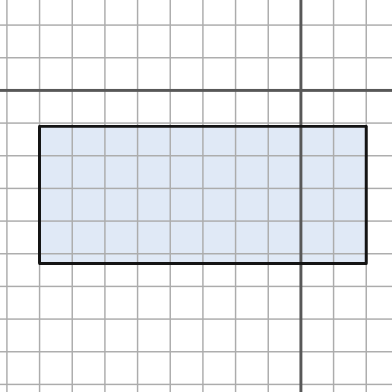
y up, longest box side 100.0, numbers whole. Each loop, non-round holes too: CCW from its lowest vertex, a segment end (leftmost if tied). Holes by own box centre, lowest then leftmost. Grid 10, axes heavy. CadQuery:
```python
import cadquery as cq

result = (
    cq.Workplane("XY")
    .moveTo(-80.0, -53.0)
    .lineTo(20.0, -53.0)
    .lineTo(20.0, -11.0)
    .lineTo(-80.0, -11.0)
    .close()
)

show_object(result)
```